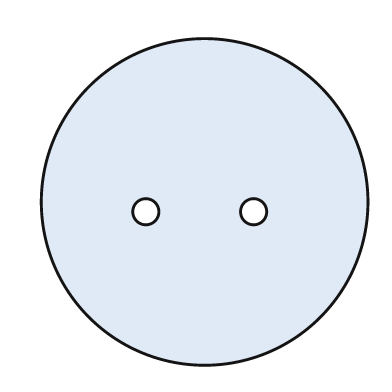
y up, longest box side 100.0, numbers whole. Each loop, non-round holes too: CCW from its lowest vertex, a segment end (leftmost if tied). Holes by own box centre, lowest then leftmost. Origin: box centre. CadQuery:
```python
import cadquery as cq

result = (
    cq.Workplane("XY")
    .moveTo(0.0, 0.0)
    .circle(50.0)
    .moveTo(-18.0, -3.0)
    .circle(4.0)
    .moveTo(15.0, -3.0)
    .circle(4.0)
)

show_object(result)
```